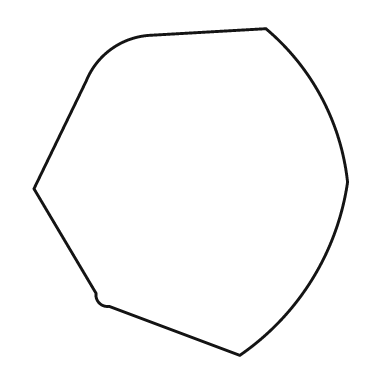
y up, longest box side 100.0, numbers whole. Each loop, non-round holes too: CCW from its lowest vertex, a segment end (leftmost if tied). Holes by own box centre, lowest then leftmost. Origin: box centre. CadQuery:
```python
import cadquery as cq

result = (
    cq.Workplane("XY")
    .moveTo(15.0, -50.0)
    .threePointArc((37.0, -27.0), (48.0, 3.0))
    .threePointArc((40.0, 29.0), (23.0, 50.0))
    .lineTo(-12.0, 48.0)
    .threePointArc((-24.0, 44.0), (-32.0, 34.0))
    .lineTo(-48.0, 1.0)
    .lineTo(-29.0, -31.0)
    .threePointArc((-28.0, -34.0), (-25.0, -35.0))
    .close()
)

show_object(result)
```